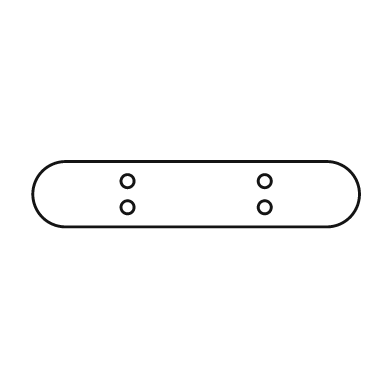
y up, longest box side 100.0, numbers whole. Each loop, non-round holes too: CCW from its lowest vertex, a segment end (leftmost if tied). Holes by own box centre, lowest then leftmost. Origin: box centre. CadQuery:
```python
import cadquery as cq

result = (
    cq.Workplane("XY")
    .moveTo(-40.0, -10.0)
    .lineTo(40.0, -10.0)
    .threePointArc((50.0, 0.0), (40.0, 10.0))
    .lineTo(-40.0, 10.0)
    .threePointArc((-50.0, 0.0), (-40.0, -10.0))
    .close()
    .moveTo(-21.0, -4.0)
    .circle(2.0)
    .moveTo(21.0, -4.0)
    .circle(2.0)
    .moveTo(-21.0, 4.0)
    .circle(2.0)
    .moveTo(21.0, 4.0)
    .circle(2.0)
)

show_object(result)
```